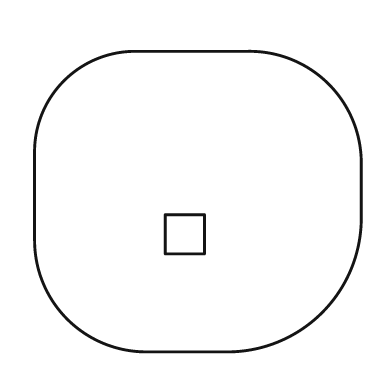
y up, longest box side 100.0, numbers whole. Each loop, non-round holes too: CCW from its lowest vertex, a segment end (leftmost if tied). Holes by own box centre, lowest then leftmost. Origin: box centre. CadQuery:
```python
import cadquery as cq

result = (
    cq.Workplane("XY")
    .moveTo(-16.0, -46.0)
    .lineTo(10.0, -46.0)
    .threePointArc((38.0, -34.0), (50.0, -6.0))
    .lineTo(50.0, 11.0)
    .threePointArc((40.0, 36.0), (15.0, 46.0))
    .lineTo(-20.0, 46.0)
    .threePointArc((-41.0, 37.0), (-50.0, 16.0))
    .lineTo(-50.0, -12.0)
    .threePointArc((-40.0, -36.0), (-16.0, -46.0))
    .close()
    .moveTo(-10.0, -16.0)
    .lineTo(2.0, -16.0)
    .lineTo(2.0, -4.0)
    .lineTo(-10.0, -4.0)
    .close()
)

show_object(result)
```